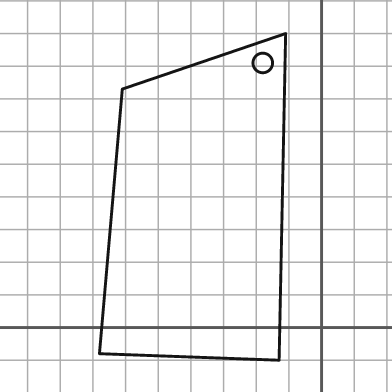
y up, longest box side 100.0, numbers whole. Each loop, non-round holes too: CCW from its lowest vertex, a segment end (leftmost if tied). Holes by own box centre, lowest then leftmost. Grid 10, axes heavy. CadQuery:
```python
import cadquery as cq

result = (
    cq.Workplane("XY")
    .moveTo(-13.0, -10.0)
    .lineTo(-11.0, 90.0)
    .lineTo(-61.0, 73.0)
    .lineTo(-68.0, -8.0)
    .close()
    .moveTo(-18.0, 81.0)
    .circle(3.0)
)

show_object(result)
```